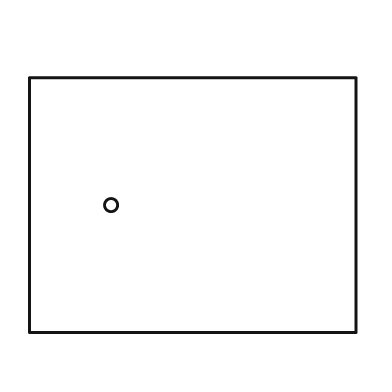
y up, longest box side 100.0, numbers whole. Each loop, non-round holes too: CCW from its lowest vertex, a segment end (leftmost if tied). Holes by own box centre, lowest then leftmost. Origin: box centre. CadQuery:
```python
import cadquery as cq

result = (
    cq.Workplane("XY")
    .moveTo(-50.0, -39.0)
    .lineTo(50.0, -39.0)
    .lineTo(50.0, 39.0)
    .lineTo(-50.0, 39.0)
    .close()
    .moveTo(-25.0, 0.0)
    .circle(2.0)
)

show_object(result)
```